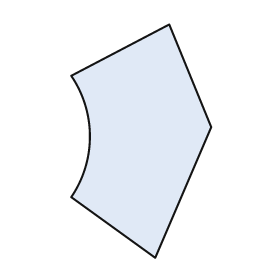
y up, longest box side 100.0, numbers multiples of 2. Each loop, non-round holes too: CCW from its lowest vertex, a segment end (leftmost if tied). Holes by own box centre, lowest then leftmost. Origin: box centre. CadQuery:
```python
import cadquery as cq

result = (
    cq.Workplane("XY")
    .moveTo(6.0, -50.0)
    .lineTo(30.0, 6.0)
    .lineTo(12.0, 50.0)
    .lineTo(-30.0, 28.0)
    .threePointArc((-22.0, 2.0), (-30.0, -24.0))
    .close()
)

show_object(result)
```